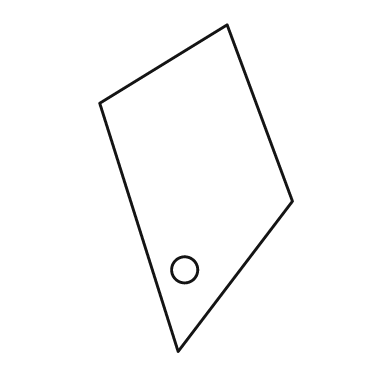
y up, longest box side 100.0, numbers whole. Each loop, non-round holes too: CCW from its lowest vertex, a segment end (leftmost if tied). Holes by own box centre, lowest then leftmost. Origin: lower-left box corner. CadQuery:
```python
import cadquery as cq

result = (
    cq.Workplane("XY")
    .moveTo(24.0, 0.0)
    .lineTo(59.0, 46.0)
    .lineTo(39.0, 100.0)
    .lineTo(0.0, 76.0)
    .close()
    .moveTo(26.0, 25.0)
    .circle(4.0)
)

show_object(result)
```